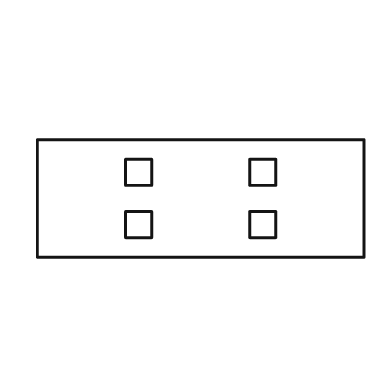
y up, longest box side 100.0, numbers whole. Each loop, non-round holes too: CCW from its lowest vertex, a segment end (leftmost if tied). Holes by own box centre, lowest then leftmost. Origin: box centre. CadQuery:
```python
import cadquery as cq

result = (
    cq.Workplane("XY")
    .moveTo(-50.0, -18.0)
    .lineTo(50.0, -18.0)
    .lineTo(50.0, 18.0)
    .lineTo(-50.0, 18.0)
    .close()
    .moveTo(-23.0, -12.0)
    .lineTo(-15.0, -12.0)
    .lineTo(-15.0, -4.0)
    .lineTo(-23.0, -4.0)
    .close()
    .moveTo(15.0, -12.0)
    .lineTo(23.0, -12.0)
    .lineTo(23.0, -4.0)
    .lineTo(15.0, -4.0)
    .close()
    .moveTo(-23.0, 4.0)
    .lineTo(-15.0, 4.0)
    .lineTo(-15.0, 12.0)
    .lineTo(-23.0, 12.0)
    .close()
    .moveTo(15.0, 4.0)
    .lineTo(23.0, 4.0)
    .lineTo(23.0, 12.0)
    .lineTo(15.0, 12.0)
    .close()
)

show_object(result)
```